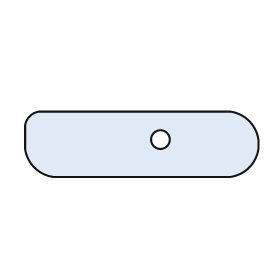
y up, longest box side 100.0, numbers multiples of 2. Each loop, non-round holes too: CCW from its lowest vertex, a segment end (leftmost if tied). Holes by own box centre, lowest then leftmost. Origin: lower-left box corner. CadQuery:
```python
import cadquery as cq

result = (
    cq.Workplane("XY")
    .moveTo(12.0, 0.0)
    .lineTo(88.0, 0.0)
    .threePointArc((96.0, 4.0), (100.0, 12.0))
    .lineTo(100.0, 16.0)
    .threePointArc((96.0, 24.0), (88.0, 28.0))
    .lineTo(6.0, 28.0)
    .threePointArc((2.0, 26.0), (0.0, 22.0))
    .lineTo(0.0, 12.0)
    .threePointArc((4.0, 4.0), (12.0, 0.0))
    .close()
    .moveTo(58.0, 16.0)
    .circle(4.0)
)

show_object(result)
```